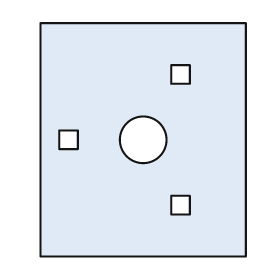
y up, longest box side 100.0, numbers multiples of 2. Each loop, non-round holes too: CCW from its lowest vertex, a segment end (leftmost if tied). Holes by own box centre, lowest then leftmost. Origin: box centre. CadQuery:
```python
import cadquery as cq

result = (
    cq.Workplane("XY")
    .moveTo(-44.0, -50.0)
    .lineTo(44.0, -50.0)
    .lineTo(44.0, 50.0)
    .lineTo(-44.0, 50.0)
    .close()
    .moveTo(12.0, -32.0)
    .lineTo(20.0, -32.0)
    .lineTo(20.0, -24.0)
    .lineTo(12.0, -24.0)
    .close()
    .moveTo(-36.0, -4.0)
    .lineTo(-28.0, -4.0)
    .lineTo(-28.0, 4.0)
    .lineTo(-36.0, 4.0)
    .close()
    .moveTo(0.0, 0.0)
    .circle(10.0)
    .moveTo(12.0, 24.0)
    .lineTo(20.0, 24.0)
    .lineTo(20.0, 32.0)
    .lineTo(12.0, 32.0)
    .close()
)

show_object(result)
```